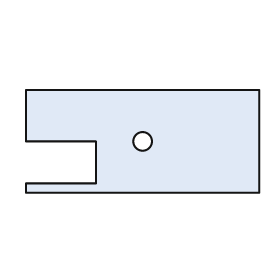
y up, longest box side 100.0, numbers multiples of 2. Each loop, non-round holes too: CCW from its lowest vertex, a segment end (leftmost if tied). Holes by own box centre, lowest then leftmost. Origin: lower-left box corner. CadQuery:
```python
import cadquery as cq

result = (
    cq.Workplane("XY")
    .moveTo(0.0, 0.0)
    .lineTo(100.0, 0.0)
    .lineTo(100.0, 44.0)
    .lineTo(0.0, 44.0)
    .lineTo(0.0, 22.0)
    .lineTo(30.0, 22.0)
    .lineTo(30.0, 4.0)
    .lineTo(0.0, 4.0)
    .close()
    .moveTo(50.0, 22.0)
    .circle(4.0)
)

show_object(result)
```